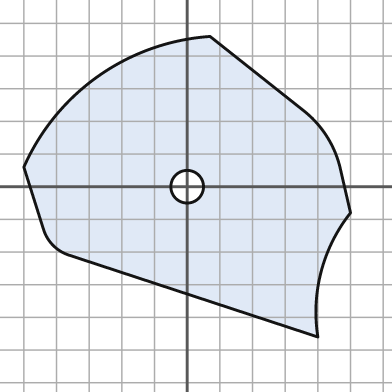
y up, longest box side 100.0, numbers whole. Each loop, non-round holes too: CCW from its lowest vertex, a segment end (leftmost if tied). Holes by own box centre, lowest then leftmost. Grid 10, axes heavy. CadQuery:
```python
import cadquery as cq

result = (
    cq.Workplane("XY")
    .moveTo(40.0, -46.0)
    .threePointArc((41.0, -26.0), (50.0, -8.0))
    .lineTo(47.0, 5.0)
    .threePointArc((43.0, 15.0), (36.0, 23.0))
    .lineTo(7.0, 46.0)
    .threePointArc((-27.0, 34.0), (-50.0, 6.0))
    .lineTo(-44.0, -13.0)
    .threePointArc((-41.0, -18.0), (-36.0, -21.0))
    .close()
    .moveTo(0.0, 0.0)
    .circle(5.0)
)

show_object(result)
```